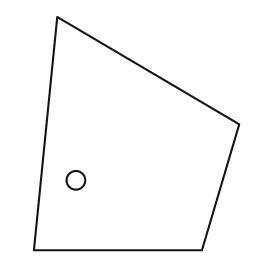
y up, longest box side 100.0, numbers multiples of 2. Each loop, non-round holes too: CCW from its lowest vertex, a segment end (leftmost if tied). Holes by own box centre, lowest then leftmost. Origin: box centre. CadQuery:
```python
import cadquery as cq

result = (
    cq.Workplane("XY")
    .moveTo(-44.0, -50.0)
    .lineTo(28.0, -50.0)
    .lineTo(44.0, 4.0)
    .lineTo(-34.0, 50.0)
    .close()
    .moveTo(-26.0, -20.0)
    .circle(4.0)
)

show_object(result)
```